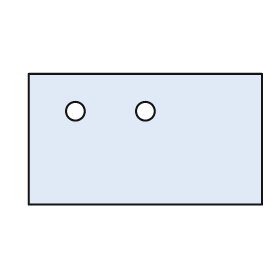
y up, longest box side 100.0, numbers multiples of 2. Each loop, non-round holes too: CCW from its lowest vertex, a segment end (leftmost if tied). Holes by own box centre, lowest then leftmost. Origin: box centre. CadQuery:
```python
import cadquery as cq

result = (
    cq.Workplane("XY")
    .moveTo(-50.0, -28.0)
    .lineTo(50.0, -28.0)
    .lineTo(50.0, 28.0)
    .lineTo(-50.0, 28.0)
    .close()
    .moveTo(-30.0, 12.0)
    .circle(4.0)
    .moveTo(0.0, 12.0)
    .circle(4.0)
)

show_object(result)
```